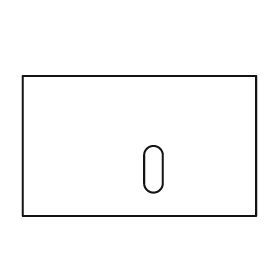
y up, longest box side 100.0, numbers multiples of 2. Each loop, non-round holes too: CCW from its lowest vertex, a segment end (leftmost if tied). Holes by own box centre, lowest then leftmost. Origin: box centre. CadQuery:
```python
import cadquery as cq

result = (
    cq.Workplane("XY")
    .moveTo(-50.0, -30.0)
    .lineTo(50.0, -30.0)
    .lineTo(50.0, 30.0)
    .lineTo(-50.0, 30.0)
    .close()
    .moveTo(2.0, -16.0)
    .threePointArc((6.0, -20.0), (10.0, -16.0))
    .lineTo(10.0, -4.0)
    .threePointArc((6.0, 0.0), (2.0, -4.0))
    .close()
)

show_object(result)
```